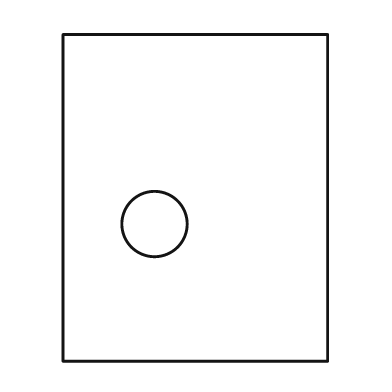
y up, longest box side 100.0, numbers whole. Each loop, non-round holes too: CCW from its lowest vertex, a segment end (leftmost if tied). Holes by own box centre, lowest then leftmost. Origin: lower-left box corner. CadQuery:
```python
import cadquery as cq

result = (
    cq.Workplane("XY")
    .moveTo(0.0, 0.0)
    .lineTo(81.0, 0.0)
    .lineTo(81.0, 100.0)
    .lineTo(0.0, 100.0)
    .close()
    .moveTo(28.0, 42.0)
    .circle(10.0)
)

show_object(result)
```